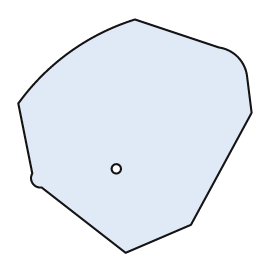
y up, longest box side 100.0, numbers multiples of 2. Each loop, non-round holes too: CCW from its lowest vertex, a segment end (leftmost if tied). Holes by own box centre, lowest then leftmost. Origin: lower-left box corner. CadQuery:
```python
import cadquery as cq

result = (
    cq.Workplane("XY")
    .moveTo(46.0, 0.0)
    .lineTo(74.0, 12.0)
    .lineTo(100.0, 60.0)
    .lineTo(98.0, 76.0)
    .threePointArc((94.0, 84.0), (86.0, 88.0))
    .lineTo(50.0, 100.0)
    .threePointArc((22.0, 86.0), (0.0, 64.0))
    .lineTo(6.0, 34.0)
    .threePointArc((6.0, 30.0), (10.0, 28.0))
    .close()
    .moveTo(42.0, 36.0)
    .circle(2.0)
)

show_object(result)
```